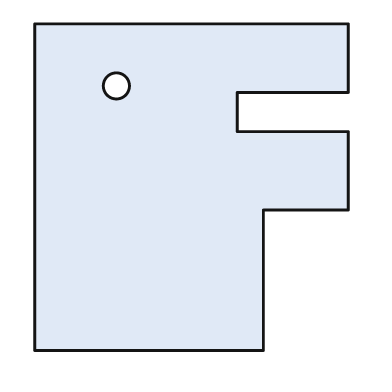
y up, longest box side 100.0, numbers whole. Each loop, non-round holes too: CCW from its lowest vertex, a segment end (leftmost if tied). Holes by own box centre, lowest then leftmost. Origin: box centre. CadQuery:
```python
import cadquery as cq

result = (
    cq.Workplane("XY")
    .moveTo(-48.0, -50.0)
    .lineTo(22.0, -50.0)
    .lineTo(22.0, -7.0)
    .lineTo(48.0, -7.0)
    .lineTo(48.0, 17.0)
    .lineTo(14.0, 17.0)
    .lineTo(14.0, 29.0)
    .lineTo(48.0, 29.0)
    .lineTo(48.0, 50.0)
    .lineTo(-48.0, 50.0)
    .close()
    .moveTo(-23.0, 31.0)
    .circle(4.0)
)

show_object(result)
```